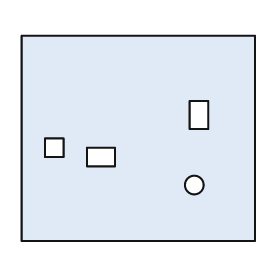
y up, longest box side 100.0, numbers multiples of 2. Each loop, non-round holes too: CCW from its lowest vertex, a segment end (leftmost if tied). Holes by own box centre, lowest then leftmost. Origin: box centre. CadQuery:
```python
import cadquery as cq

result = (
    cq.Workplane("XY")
    .moveTo(-50.0, -44.0)
    .lineTo(50.0, -44.0)
    .lineTo(50.0, 44.0)
    .lineTo(-50.0, 44.0)
    .close()
    .moveTo(24.0, -20.0)
    .circle(4.0)
    .moveTo(-22.0, -12.0)
    .lineTo(-10.0, -12.0)
    .lineTo(-10.0, -4.0)
    .lineTo(-22.0, -4.0)
    .close()
    .moveTo(-40.0, -8.0)
    .lineTo(-32.0, -8.0)
    .lineTo(-32.0, 0.0)
    .lineTo(-40.0, 0.0)
    .close()
    .moveTo(22.0, 4.0)
    .lineTo(30.0, 4.0)
    .lineTo(30.0, 16.0)
    .lineTo(22.0, 16.0)
    .close()
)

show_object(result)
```